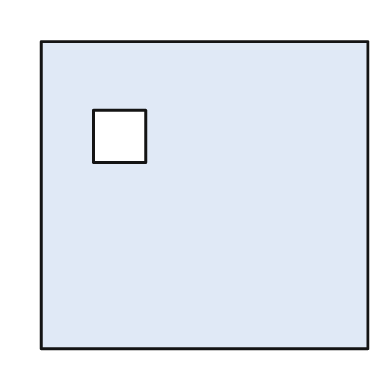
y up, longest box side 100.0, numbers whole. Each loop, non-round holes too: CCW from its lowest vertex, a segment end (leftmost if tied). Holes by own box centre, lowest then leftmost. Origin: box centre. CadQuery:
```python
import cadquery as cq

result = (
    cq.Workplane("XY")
    .moveTo(-50.0, -47.0)
    .lineTo(50.0, -47.0)
    .lineTo(50.0, 47.0)
    .lineTo(-50.0, 47.0)
    .close()
    .moveTo(-34.0, 10.0)
    .lineTo(-18.0, 10.0)
    .lineTo(-18.0, 26.0)
    .lineTo(-34.0, 26.0)
    .close()
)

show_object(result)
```